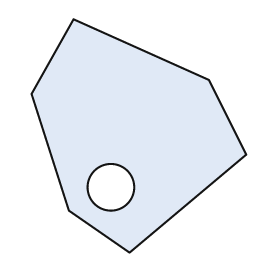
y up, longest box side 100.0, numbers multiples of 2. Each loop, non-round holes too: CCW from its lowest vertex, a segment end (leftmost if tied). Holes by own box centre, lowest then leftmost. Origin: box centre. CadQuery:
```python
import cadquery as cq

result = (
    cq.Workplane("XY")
    .moveTo(-4.0, -50.0)
    .lineTo(46.0, -8.0)
    .lineTo(30.0, 24.0)
    .lineTo(-28.0, 50.0)
    .lineTo(-46.0, 18.0)
    .lineTo(-30.0, -32.0)
    .close()
    .moveTo(-12.0, -22.0)
    .circle(10.0)
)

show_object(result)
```